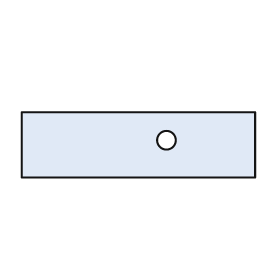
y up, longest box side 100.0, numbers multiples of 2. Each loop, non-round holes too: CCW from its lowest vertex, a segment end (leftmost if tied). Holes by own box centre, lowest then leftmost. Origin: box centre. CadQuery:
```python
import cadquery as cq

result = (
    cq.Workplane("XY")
    .moveTo(-50.0, -14.0)
    .lineTo(50.0, -14.0)
    .lineTo(50.0, 14.0)
    .lineTo(-50.0, 14.0)
    .close()
    .moveTo(12.0, 2.0)
    .circle(4.0)
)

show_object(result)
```